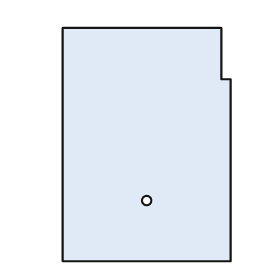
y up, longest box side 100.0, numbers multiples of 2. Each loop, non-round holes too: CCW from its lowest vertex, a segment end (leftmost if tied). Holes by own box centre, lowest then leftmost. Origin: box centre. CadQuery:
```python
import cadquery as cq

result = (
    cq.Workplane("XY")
    .moveTo(-36.0, -50.0)
    .lineTo(36.0, -50.0)
    .lineTo(36.0, 28.0)
    .lineTo(32.0, 28.0)
    .lineTo(32.0, 50.0)
    .lineTo(-36.0, 50.0)
    .close()
    .moveTo(0.0, -24.0)
    .circle(2.0)
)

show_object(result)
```